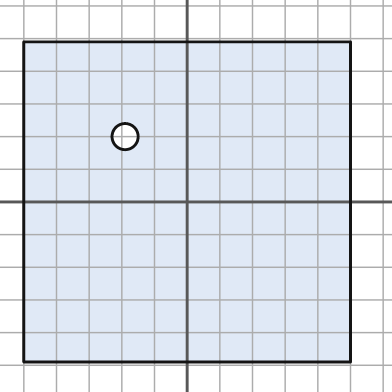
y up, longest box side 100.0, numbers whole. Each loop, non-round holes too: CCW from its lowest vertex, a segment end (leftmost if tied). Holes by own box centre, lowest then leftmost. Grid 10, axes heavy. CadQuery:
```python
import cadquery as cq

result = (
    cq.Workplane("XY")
    .moveTo(-50.0, -49.0)
    .lineTo(50.0, -49.0)
    .lineTo(50.0, 49.0)
    .lineTo(-50.0, 49.0)
    .close()
    .moveTo(-19.0, 20.0)
    .circle(4.0)
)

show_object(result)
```